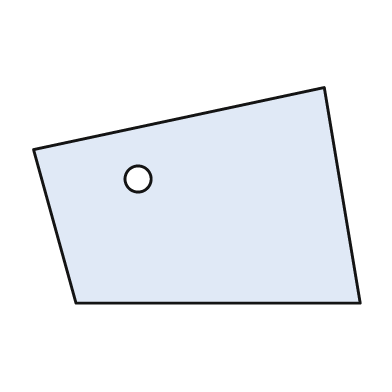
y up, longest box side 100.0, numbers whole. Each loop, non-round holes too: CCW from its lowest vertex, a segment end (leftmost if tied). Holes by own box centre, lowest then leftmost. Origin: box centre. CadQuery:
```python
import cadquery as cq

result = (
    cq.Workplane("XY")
    .moveTo(-37.0, -33.0)
    .lineTo(50.0, -33.0)
    .lineTo(39.0, 33.0)
    .lineTo(-50.0, 14.0)
    .close()
    .moveTo(-18.0, 5.0)
    .circle(4.0)
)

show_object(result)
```